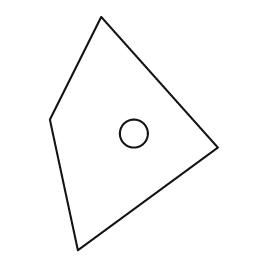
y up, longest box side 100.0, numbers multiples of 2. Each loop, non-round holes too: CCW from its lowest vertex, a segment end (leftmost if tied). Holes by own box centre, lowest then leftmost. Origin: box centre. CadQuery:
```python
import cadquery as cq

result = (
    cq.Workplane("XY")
    .moveTo(-24.0, -50.0)
    .lineTo(36.0, -6.0)
    .lineTo(-14.0, 50.0)
    .lineTo(-36.0, 6.0)
    .close()
    .moveTo(0.0, 0.0)
    .circle(6.0)
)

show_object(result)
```